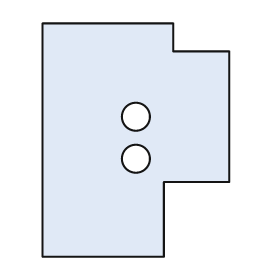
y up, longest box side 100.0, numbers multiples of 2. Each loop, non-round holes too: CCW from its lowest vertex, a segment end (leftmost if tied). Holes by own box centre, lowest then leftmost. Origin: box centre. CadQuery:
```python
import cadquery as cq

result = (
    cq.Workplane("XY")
    .moveTo(-40.0, -50.0)
    .lineTo(12.0, -50.0)
    .lineTo(12.0, -18.0)
    .lineTo(40.0, -18.0)
    .lineTo(40.0, 38.0)
    .lineTo(16.0, 38.0)
    .lineTo(16.0, 50.0)
    .lineTo(-40.0, 50.0)
    .close()
    .moveTo(0.0, -8.0)
    .circle(6.0)
    .moveTo(0.0, 10.0)
    .circle(6.0)
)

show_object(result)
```